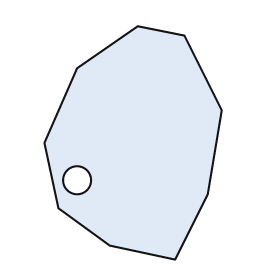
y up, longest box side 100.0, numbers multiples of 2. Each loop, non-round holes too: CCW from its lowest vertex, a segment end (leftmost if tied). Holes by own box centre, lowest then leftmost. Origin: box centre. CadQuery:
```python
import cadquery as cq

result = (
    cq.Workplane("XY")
    .moveTo(18.0, -50.0)
    .lineTo(32.0, -22.0)
    .lineTo(38.0, 14.0)
    .lineTo(22.0, 46.0)
    .lineTo(2.0, 50.0)
    .lineTo(-24.0, 32.0)
    .lineTo(-38.0, 0.0)
    .lineTo(-32.0, -28.0)
    .lineTo(-10.0, -44.0)
    .close()
    .moveTo(-24.0, -16.0)
    .circle(6.0)
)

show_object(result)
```